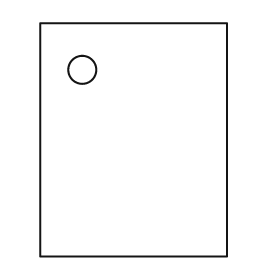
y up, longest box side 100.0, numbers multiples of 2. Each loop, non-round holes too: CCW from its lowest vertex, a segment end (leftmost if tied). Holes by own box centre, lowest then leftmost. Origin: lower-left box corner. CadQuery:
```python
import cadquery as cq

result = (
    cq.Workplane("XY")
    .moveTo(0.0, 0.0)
    .lineTo(80.0, 0.0)
    .lineTo(80.0, 100.0)
    .lineTo(0.0, 100.0)
    .close()
    .moveTo(18.0, 80.0)
    .circle(6.0)
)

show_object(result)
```